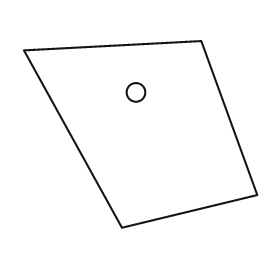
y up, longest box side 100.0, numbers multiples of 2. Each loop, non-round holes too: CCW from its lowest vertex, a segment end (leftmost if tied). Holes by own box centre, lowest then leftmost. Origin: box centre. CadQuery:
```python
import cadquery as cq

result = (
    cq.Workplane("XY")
    .moveTo(-8.0, -40.0)
    .lineTo(50.0, -26.0)
    .lineTo(26.0, 40.0)
    .lineTo(-50.0, 36.0)
    .close()
    .moveTo(-2.0, 18.0)
    .circle(4.0)
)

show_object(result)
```